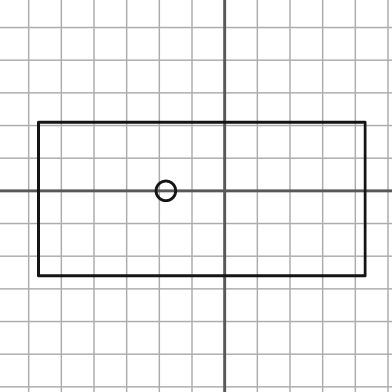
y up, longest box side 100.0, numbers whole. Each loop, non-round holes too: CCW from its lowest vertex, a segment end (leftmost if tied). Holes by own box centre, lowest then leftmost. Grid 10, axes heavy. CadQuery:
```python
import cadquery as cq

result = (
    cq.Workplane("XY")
    .moveTo(-57.0, -26.0)
    .lineTo(43.0, -26.0)
    .lineTo(43.0, 21.0)
    .lineTo(-57.0, 21.0)
    .close()
    .moveTo(-18.0, 0.0)
    .circle(3.0)
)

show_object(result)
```